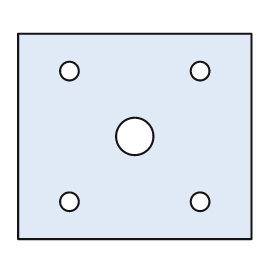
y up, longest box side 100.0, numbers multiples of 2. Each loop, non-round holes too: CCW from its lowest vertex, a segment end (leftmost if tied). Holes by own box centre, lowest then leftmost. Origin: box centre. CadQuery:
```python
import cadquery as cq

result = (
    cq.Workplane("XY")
    .moveTo(-50.0, -44.0)
    .lineTo(50.0, -44.0)
    .lineTo(50.0, 44.0)
    .lineTo(-50.0, 44.0)
    .close()
    .moveTo(-28.0, -28.0)
    .circle(4.0)
    .moveTo(28.0, -28.0)
    .circle(4.0)
    .moveTo(0.0, 0.0)
    .circle(8.0)
    .moveTo(-28.0, 28.0)
    .circle(4.0)
    .moveTo(28.0, 28.0)
    .circle(4.0)
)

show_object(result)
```